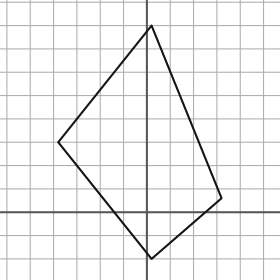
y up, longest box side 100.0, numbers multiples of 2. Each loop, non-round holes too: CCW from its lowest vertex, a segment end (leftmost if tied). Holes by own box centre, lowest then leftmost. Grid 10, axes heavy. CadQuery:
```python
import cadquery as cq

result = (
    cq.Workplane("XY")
    .moveTo(2.0, -20.0)
    .lineTo(32.0, 6.0)
    .lineTo(2.0, 80.0)
    .lineTo(-38.0, 30.0)
    .close()
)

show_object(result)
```